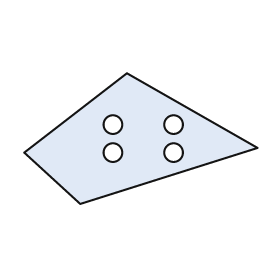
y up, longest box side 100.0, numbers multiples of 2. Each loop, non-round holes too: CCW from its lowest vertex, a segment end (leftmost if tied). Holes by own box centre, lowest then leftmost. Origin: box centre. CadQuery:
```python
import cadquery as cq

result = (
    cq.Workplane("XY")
    .moveTo(-26.0, -28.0)
    .lineTo(50.0, -4.0)
    .lineTo(-6.0, 28.0)
    .lineTo(-50.0, -6.0)
    .close()
    .moveTo(-12.0, -6.0)
    .circle(4.0)
    .moveTo(14.0, -6.0)
    .circle(4.0)
    .moveTo(-12.0, 6.0)
    .circle(4.0)
    .moveTo(14.0, 6.0)
    .circle(4.0)
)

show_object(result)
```